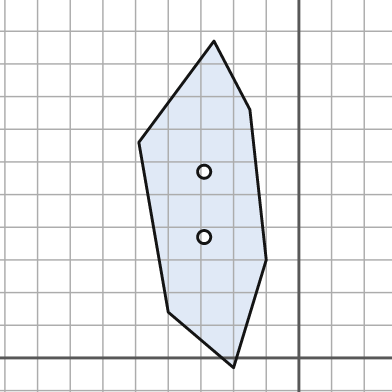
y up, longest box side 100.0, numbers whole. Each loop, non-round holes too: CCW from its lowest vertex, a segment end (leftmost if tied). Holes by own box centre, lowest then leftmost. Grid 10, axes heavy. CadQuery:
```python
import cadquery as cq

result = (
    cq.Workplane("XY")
    .moveTo(-20.0, -3.0)
    .lineTo(-10.0, 30.0)
    .lineTo(-15.0, 76.0)
    .lineTo(-26.0, 97.0)
    .lineTo(-49.0, 66.0)
    .lineTo(-40.0, 14.0)
    .close()
    .moveTo(-29.0, 37.0)
    .circle(2.0)
    .moveTo(-29.0, 57.0)
    .circle(2.0)
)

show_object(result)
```